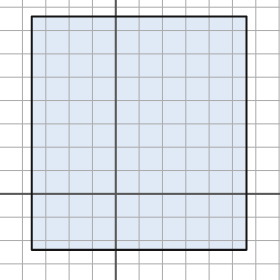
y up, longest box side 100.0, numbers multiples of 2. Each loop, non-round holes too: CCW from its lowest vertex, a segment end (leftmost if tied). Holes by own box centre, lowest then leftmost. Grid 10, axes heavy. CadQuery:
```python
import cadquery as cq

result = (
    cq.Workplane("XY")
    .moveTo(-36.0, -24.0)
    .lineTo(56.0, -24.0)
    .lineTo(56.0, 76.0)
    .lineTo(-36.0, 76.0)
    .close()
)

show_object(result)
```